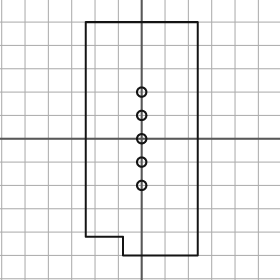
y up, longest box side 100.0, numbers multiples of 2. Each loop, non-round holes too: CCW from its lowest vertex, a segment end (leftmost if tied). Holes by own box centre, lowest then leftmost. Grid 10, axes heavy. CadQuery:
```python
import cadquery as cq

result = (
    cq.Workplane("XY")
    .moveTo(-8.0, -50.0)
    .lineTo(24.0, -50.0)
    .lineTo(24.0, 50.0)
    .lineTo(-24.0, 50.0)
    .lineTo(-24.0, -42.0)
    .lineTo(-8.0, -42.0)
    .close()
    .moveTo(0.0, -20.0)
    .circle(2.0)
    .moveTo(0.0, -10.0)
    .circle(2.0)
    .moveTo(0.0, 0.0)
    .circle(2.0)
    .moveTo(0.0, 10.0)
    .circle(2.0)
    .moveTo(0.0, 20.0)
    .circle(2.0)
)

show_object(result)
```